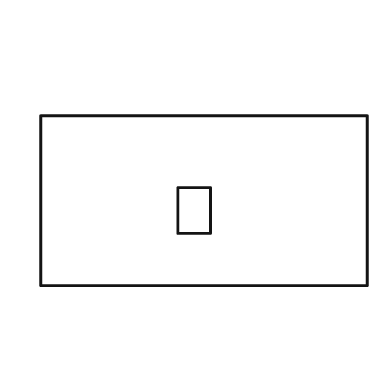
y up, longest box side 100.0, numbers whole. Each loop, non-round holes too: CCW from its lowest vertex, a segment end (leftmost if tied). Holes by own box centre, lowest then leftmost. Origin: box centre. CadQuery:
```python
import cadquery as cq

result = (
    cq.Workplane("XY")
    .moveTo(-50.0, -26.0)
    .lineTo(50.0, -26.0)
    .lineTo(50.0, 26.0)
    .lineTo(-50.0, 26.0)
    .close()
    .moveTo(-8.0, -10.0)
    .lineTo(2.0, -10.0)
    .lineTo(2.0, 4.0)
    .lineTo(-8.0, 4.0)
    .close()
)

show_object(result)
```